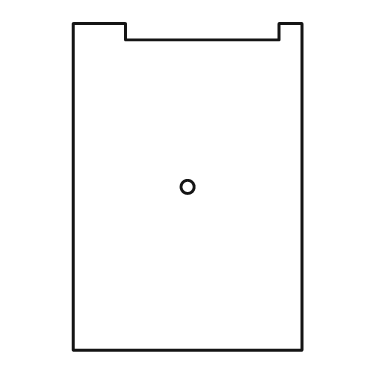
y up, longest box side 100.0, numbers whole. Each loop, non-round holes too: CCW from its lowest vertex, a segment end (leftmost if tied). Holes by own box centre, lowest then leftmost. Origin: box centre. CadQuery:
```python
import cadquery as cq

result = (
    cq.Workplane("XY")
    .moveTo(-35.0, -50.0)
    .lineTo(35.0, -50.0)
    .lineTo(35.0, 50.0)
    .lineTo(28.0, 50.0)
    .lineTo(28.0, 45.0)
    .lineTo(-19.0, 45.0)
    .lineTo(-19.0, 50.0)
    .lineTo(-35.0, 50.0)
    .close()
    .moveTo(0.0, 0.0)
    .circle(2.0)
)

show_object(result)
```